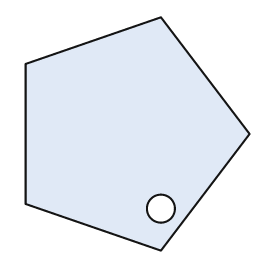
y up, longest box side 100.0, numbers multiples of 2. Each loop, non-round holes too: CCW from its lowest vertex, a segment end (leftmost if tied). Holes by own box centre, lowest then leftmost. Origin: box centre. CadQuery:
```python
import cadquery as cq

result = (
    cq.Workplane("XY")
    .moveTo(10.0, -50.0)
    .lineTo(48.0, 0.0)
    .lineTo(10.0, 50.0)
    .lineTo(-48.0, 30.0)
    .lineTo(-48.0, -30.0)
    .close()
    .moveTo(10.0, -32.0)
    .circle(6.0)
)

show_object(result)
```